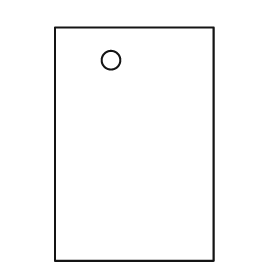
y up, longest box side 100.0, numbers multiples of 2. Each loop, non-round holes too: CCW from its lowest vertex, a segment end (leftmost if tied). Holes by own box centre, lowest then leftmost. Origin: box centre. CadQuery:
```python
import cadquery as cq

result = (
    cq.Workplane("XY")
    .moveTo(-34.0, -50.0)
    .lineTo(34.0, -50.0)
    .lineTo(34.0, 50.0)
    .lineTo(-34.0, 50.0)
    .close()
    .moveTo(-10.0, 36.0)
    .circle(4.0)
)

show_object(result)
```